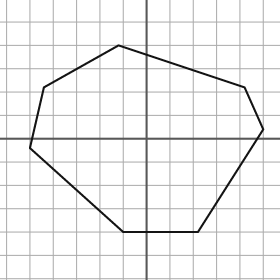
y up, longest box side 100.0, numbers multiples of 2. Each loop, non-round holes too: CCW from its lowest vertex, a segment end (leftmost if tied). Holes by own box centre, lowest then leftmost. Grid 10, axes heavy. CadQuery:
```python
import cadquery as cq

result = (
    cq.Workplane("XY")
    .moveTo(-10.0, -40.0)
    .lineTo(22.0, -40.0)
    .lineTo(50.0, 4.0)
    .lineTo(42.0, 22.0)
    .lineTo(-12.0, 40.0)
    .lineTo(-44.0, 22.0)
    .lineTo(-50.0, -4.0)
    .close()
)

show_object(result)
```